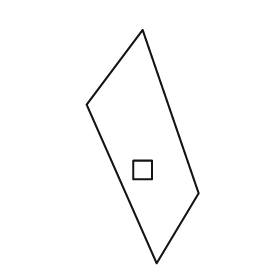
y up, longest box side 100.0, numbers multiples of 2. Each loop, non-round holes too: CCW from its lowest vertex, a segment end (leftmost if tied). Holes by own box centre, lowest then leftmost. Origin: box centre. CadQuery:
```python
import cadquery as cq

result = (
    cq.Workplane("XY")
    .moveTo(6.0, -50.0)
    .lineTo(24.0, -20.0)
    .lineTo(0.0, 50.0)
    .lineTo(-24.0, 18.0)
    .close()
    .moveTo(-4.0, -14.0)
    .lineTo(4.0, -14.0)
    .lineTo(4.0, -6.0)
    .lineTo(-4.0, -6.0)
    .close()
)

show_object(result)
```